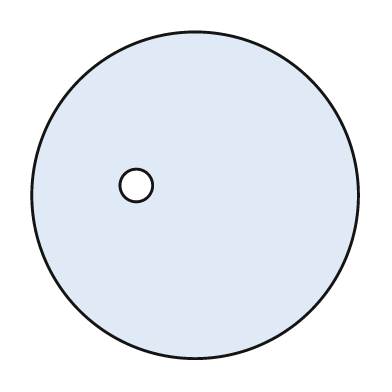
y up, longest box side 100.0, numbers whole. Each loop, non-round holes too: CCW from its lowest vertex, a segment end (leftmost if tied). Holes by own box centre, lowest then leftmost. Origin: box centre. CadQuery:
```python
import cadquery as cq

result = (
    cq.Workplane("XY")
    .moveTo(0.0, 0.0)
    .circle(50.0)
    .moveTo(-18.0, 3.0)
    .circle(5.0)
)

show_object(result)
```